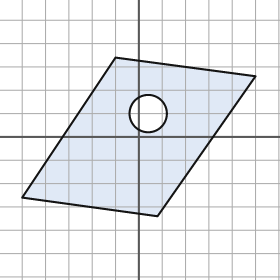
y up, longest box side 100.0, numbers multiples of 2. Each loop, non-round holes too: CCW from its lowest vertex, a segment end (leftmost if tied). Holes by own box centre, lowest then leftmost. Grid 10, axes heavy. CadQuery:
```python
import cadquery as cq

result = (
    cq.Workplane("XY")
    .moveTo(8.0, -34.0)
    .lineTo(50.0, 26.0)
    .lineTo(-10.0, 34.0)
    .lineTo(-50.0, -26.0)
    .close()
    .moveTo(4.0, 10.0)
    .circle(8.0)
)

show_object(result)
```